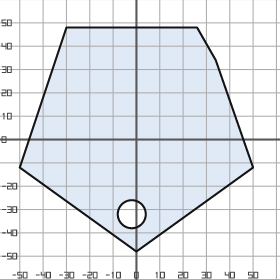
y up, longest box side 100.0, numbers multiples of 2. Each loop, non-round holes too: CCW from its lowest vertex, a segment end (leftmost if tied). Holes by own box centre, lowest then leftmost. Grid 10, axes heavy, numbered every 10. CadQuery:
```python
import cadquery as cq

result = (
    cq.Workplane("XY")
    .moveTo(0.0, -48.0)
    .lineTo(50.0, -12.0)
    .lineTo(34.0, 34.0)
    .lineTo(26.0, 48.0)
    .lineTo(-30.0, 48.0)
    .lineTo(-50.0, -12.0)
    .close()
    .moveTo(-2.0, -32.0)
    .circle(6.0)
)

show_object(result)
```